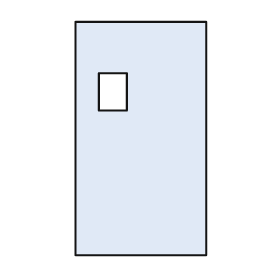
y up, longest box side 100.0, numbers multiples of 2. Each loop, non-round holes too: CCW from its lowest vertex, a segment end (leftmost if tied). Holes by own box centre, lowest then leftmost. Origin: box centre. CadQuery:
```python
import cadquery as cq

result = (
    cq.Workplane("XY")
    .moveTo(-28.0, -50.0)
    .lineTo(28.0, -50.0)
    .lineTo(28.0, 50.0)
    .lineTo(-28.0, 50.0)
    .close()
    .moveTo(-18.0, 12.0)
    .lineTo(-6.0, 12.0)
    .lineTo(-6.0, 28.0)
    .lineTo(-18.0, 28.0)
    .close()
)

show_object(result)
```